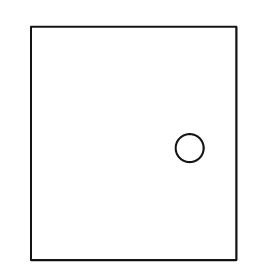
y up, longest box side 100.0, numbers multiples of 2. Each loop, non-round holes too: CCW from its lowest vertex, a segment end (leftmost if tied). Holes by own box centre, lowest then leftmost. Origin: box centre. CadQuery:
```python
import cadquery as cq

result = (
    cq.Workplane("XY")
    .moveTo(-44.0, -50.0)
    .lineTo(44.0, -50.0)
    .lineTo(44.0, 50.0)
    .lineTo(-44.0, 50.0)
    .close()
    .moveTo(24.0, -2.0)
    .circle(6.0)
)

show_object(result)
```